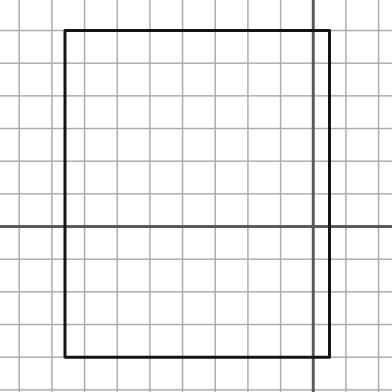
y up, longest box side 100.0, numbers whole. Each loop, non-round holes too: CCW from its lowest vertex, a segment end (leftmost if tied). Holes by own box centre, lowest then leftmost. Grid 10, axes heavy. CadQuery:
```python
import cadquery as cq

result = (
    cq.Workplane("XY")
    .moveTo(-76.0, -40.0)
    .lineTo(5.0, -40.0)
    .lineTo(5.0, 60.0)
    .lineTo(-76.0, 60.0)
    .close()
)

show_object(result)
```